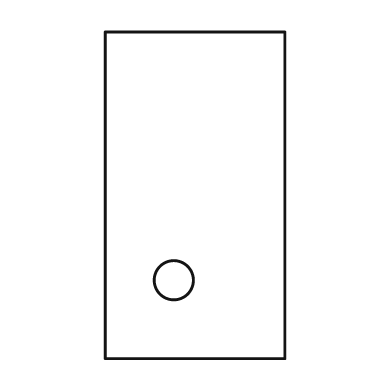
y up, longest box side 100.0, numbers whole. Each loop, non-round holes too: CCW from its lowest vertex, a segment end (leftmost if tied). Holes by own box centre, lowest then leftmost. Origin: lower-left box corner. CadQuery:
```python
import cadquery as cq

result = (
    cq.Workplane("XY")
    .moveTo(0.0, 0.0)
    .lineTo(55.0, 0.0)
    .lineTo(55.0, 100.0)
    .lineTo(0.0, 100.0)
    .close()
    .moveTo(21.0, 24.0)
    .circle(6.0)
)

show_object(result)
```